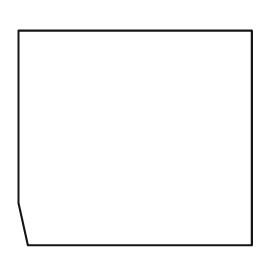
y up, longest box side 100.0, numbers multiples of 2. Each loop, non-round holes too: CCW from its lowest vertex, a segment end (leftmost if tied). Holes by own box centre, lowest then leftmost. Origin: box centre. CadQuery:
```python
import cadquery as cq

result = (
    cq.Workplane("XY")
    .moveTo(-46.0, -46.0)
    .lineTo(50.0, -46.0)
    .lineTo(50.0, 46.0)
    .lineTo(-50.0, 46.0)
    .lineTo(-50.0, -28.0)
    .close()
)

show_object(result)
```